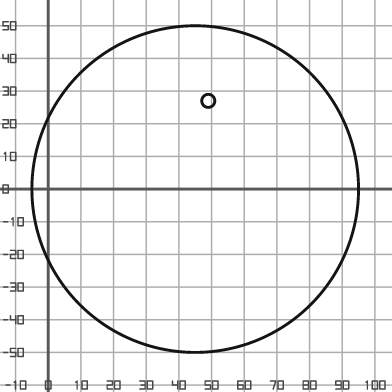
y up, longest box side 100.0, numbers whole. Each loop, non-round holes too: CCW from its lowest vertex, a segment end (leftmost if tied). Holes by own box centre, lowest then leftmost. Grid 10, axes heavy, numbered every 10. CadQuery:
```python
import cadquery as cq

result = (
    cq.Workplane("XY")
    .moveTo(45.0, 0.0)
    .circle(50.0)
    .moveTo(49.0, 27.0)
    .circle(2.0)
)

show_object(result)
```